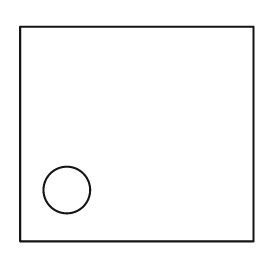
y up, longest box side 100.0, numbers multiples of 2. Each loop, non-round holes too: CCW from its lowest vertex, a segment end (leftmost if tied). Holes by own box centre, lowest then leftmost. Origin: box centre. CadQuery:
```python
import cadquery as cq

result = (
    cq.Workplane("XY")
    .moveTo(-50.0, -46.0)
    .lineTo(50.0, -46.0)
    .lineTo(50.0, 46.0)
    .lineTo(-50.0, 46.0)
    .close()
    .moveTo(-30.0, -24.0)
    .circle(10.0)
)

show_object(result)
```